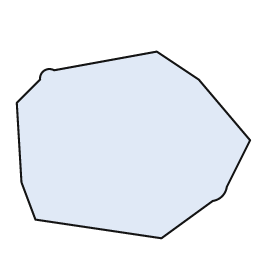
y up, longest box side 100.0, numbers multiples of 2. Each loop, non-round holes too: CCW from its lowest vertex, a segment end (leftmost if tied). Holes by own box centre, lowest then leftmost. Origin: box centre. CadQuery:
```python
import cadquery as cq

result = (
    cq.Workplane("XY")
    .moveTo(12.0, -40.0)
    .lineTo(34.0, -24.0)
    .threePointArc((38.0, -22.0), (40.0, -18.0))
    .lineTo(50.0, 2.0)
    .lineTo(28.0, 28.0)
    .lineTo(10.0, 40.0)
    .lineTo(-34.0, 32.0)
    .threePointArc((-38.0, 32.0), (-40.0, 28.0))
    .lineTo(-50.0, 18.0)
    .lineTo(-48.0, -16.0)
    .lineTo(-42.0, -32.0)
    .close()
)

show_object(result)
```